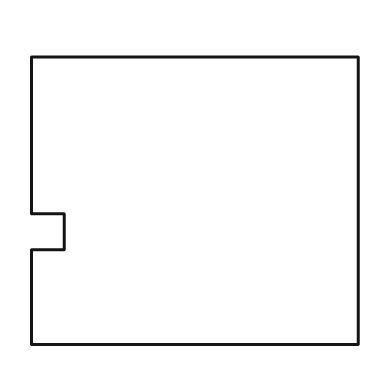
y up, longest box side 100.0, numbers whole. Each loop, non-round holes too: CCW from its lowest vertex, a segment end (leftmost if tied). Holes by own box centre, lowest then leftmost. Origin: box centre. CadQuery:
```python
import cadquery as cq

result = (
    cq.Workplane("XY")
    .moveTo(-50.0, -44.0)
    .lineTo(50.0, -44.0)
    .lineTo(50.0, 44.0)
    .lineTo(-50.0, 44.0)
    .lineTo(-50.0, -4.0)
    .lineTo(-40.0, -4.0)
    .lineTo(-40.0, -15.0)
    .lineTo(-50.0, -15.0)
    .close()
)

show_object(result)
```